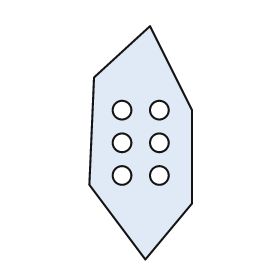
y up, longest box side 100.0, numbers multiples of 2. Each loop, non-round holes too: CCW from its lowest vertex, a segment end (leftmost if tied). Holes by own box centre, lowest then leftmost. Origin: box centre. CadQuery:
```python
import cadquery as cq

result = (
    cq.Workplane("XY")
    .moveTo(2.0, -50.0)
    .lineTo(22.0, -26.0)
    .lineTo(22.0, 14.0)
    .lineTo(4.0, 50.0)
    .lineTo(-20.0, 28.0)
    .lineTo(-22.0, -18.0)
    .close()
    .moveTo(-8.0, -14.0)
    .circle(4.0)
    .moveTo(8.0, -14.0)
    .circle(4.0)
    .moveTo(-8.0, 0.0)
    .circle(4.0)
    .moveTo(8.0, 0.0)
    .circle(4.0)
    .moveTo(-8.0, 14.0)
    .circle(4.0)
    .moveTo(8.0, 14.0)
    .circle(4.0)
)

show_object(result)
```